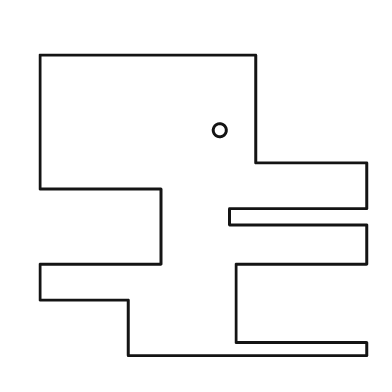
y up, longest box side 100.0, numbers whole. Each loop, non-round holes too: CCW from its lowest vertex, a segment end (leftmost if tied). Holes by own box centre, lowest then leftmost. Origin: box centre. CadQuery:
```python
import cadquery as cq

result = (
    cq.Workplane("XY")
    .moveTo(-23.0, -46.0)
    .lineTo(50.0, -46.0)
    .lineTo(50.0, -42.0)
    .lineTo(10.0, -42.0)
    .lineTo(10.0, -18.0)
    .lineTo(50.0, -18.0)
    .lineTo(50.0, -6.0)
    .lineTo(8.0, -6.0)
    .lineTo(8.0, -1.0)
    .lineTo(50.0, -1.0)
    .lineTo(50.0, 13.0)
    .lineTo(16.0, 13.0)
    .lineTo(16.0, 46.0)
    .lineTo(-50.0, 46.0)
    .lineTo(-50.0, 5.0)
    .lineTo(-13.0, 5.0)
    .lineTo(-13.0, -18.0)
    .lineTo(-50.0, -18.0)
    .lineTo(-50.0, -29.0)
    .lineTo(-23.0, -29.0)
    .close()
    .moveTo(5.0, 23.0)
    .circle(2.0)
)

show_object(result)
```